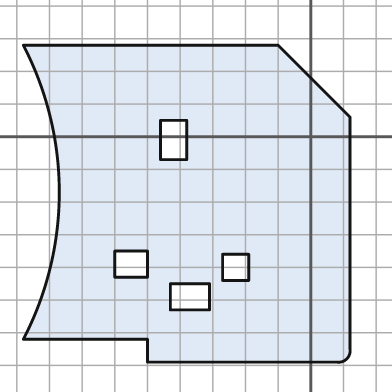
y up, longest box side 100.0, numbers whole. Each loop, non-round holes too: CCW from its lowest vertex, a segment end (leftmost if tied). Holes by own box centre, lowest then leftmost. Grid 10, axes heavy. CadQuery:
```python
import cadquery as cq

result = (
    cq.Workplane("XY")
    .moveTo(-50.0, -69.0)
    .lineTo(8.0, -69.0)
    .threePointArc((11.0, -68.0), (12.0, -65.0))
    .lineTo(12.0, 6.0)
    .lineTo(-10.0, 28.0)
    .lineTo(-88.0, 28.0)
    .threePointArc((-77.0, -17.0), (-88.0, -62.0))
    .lineTo(-50.0, -62.0)
    .close()
    .moveTo(-43.0, -53.0)
    .lineTo(-31.0, -53.0)
    .lineTo(-31.0, -45.0)
    .lineTo(-43.0, -45.0)
    .close()
    .moveTo(-27.0, -44.0)
    .lineTo(-19.0, -44.0)
    .lineTo(-19.0, -36.0)
    .lineTo(-27.0, -36.0)
    .close()
    .moveTo(-60.0, -43.0)
    .lineTo(-50.0, -43.0)
    .lineTo(-50.0, -35.0)
    .lineTo(-60.0, -35.0)
    .close()
    .moveTo(-46.0, -7.0)
    .lineTo(-38.0, -7.0)
    .lineTo(-38.0, 5.0)
    .lineTo(-46.0, 5.0)
    .close()
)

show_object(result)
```